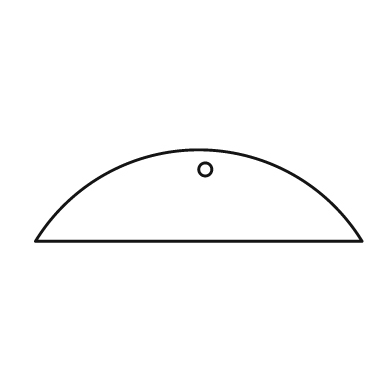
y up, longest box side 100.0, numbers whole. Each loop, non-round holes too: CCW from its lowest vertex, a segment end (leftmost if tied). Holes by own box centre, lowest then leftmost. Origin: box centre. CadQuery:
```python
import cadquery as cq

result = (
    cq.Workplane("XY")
    .moveTo(-50.0, -14.0)
    .lineTo(50.0, -14.0)
    .threePointArc((0.0, 14.0), (-50.0, -14.0))
    .close()
    .moveTo(2.0, 8.0)
    .circle(2.0)
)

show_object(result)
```